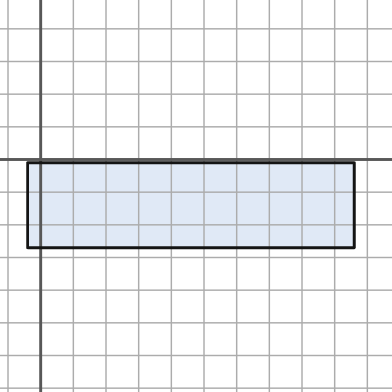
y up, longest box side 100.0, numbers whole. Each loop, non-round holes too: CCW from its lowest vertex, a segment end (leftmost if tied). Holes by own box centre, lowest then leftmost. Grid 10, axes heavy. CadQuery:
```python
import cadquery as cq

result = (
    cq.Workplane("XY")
    .moveTo(-4.0, -27.0)
    .lineTo(96.0, -27.0)
    .lineTo(96.0, -1.0)
    .lineTo(-4.0, -1.0)
    .close()
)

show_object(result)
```